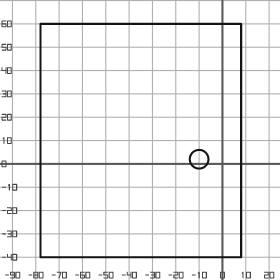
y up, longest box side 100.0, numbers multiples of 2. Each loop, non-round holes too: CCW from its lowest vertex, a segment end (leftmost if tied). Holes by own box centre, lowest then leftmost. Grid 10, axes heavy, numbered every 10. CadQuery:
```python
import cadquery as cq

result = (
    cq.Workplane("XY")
    .moveTo(-78.0, -40.0)
    .lineTo(8.0, -40.0)
    .lineTo(8.0, 60.0)
    .lineTo(-78.0, 60.0)
    .close()
    .moveTo(-10.0, 2.0)
    .circle(4.0)
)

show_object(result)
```